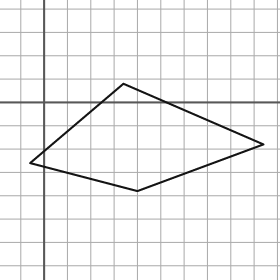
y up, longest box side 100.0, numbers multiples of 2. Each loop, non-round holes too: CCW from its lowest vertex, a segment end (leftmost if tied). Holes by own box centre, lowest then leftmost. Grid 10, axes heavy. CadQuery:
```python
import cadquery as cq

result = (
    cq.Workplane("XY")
    .moveTo(40.0, -38.0)
    .lineTo(94.0, -18.0)
    .lineTo(34.0, 8.0)
    .lineTo(-6.0, -26.0)
    .close()
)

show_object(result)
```